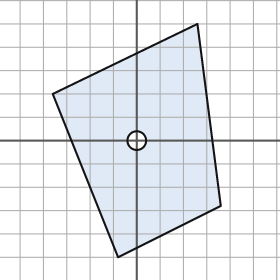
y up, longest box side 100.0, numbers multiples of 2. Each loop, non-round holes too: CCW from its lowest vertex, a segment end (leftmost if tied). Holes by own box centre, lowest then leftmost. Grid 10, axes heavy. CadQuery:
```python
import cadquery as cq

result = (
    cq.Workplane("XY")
    .moveTo(-8.0, -50.0)
    .lineTo(36.0, -28.0)
    .lineTo(26.0, 50.0)
    .lineTo(-36.0, 20.0)
    .close()
    .moveTo(0.0, 0.0)
    .circle(4.0)
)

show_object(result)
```